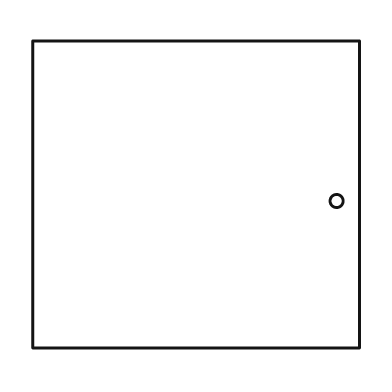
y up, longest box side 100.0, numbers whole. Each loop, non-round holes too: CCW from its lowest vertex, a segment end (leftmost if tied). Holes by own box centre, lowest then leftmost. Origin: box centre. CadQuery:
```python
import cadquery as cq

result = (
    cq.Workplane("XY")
    .moveTo(-50.0, -47.0)
    .lineTo(50.0, -47.0)
    .lineTo(50.0, 47.0)
    .lineTo(-50.0, 47.0)
    .close()
    .moveTo(43.0, -2.0)
    .circle(2.0)
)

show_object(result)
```